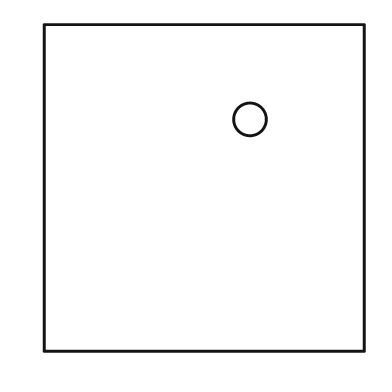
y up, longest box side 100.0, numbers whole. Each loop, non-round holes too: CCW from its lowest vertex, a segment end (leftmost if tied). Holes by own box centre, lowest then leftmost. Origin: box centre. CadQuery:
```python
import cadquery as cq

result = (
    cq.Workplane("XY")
    .moveTo(-49.0, -50.0)
    .lineTo(49.0, -50.0)
    .lineTo(49.0, 50.0)
    .lineTo(-49.0, 50.0)
    .close()
    .moveTo(14.0, 21.0)
    .circle(5.0)
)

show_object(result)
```